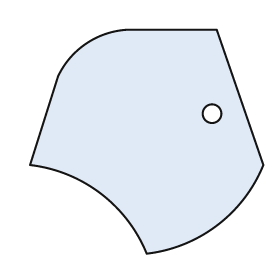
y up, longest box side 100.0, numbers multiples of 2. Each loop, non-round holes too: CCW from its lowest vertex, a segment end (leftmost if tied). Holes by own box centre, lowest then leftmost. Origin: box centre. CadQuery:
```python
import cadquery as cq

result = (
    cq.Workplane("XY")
    .moveTo(0.0, -48.0)
    .threePointArc((30.0, -36.0), (50.0, -10.0))
    .lineTo(30.0, 48.0)
    .lineTo(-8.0, 48.0)
    .threePointArc((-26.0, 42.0), (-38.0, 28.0))
    .lineTo(-50.0, -10.0)
    .threePointArc((-20.0, -22.0), (0.0, -48.0))
    .close()
    .moveTo(28.0, 12.0)
    .circle(4.0)
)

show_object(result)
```